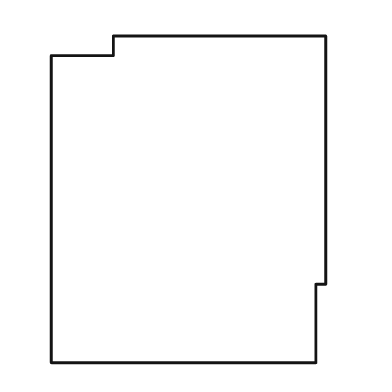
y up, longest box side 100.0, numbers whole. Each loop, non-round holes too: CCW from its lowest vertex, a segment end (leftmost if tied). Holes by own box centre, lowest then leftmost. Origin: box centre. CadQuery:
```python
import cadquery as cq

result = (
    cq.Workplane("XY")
    .moveTo(-42.0, -50.0)
    .lineTo(39.0, -50.0)
    .lineTo(39.0, -26.0)
    .lineTo(42.0, -26.0)
    .lineTo(42.0, 50.0)
    .lineTo(-23.0, 50.0)
    .lineTo(-23.0, 44.0)
    .lineTo(-42.0, 44.0)
    .close()
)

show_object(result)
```